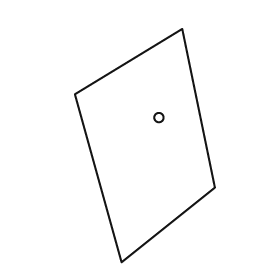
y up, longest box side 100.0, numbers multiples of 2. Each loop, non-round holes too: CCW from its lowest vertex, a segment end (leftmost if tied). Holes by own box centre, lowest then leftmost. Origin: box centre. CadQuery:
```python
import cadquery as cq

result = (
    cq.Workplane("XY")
    .moveTo(-10.0, -50.0)
    .lineTo(30.0, -18.0)
    .lineTo(16.0, 50.0)
    .lineTo(-30.0, 22.0)
    .close()
    .moveTo(6.0, 12.0)
    .circle(2.0)
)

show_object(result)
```